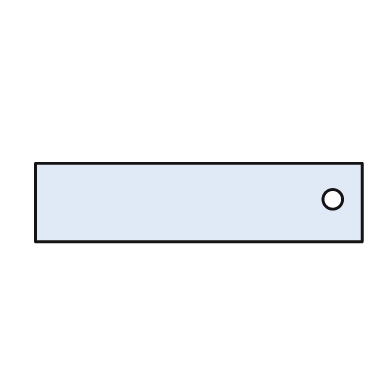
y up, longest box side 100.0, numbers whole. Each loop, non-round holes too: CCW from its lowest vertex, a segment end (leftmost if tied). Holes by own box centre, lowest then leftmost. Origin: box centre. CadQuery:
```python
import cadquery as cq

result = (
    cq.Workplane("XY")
    .moveTo(-50.0, -12.0)
    .lineTo(50.0, -12.0)
    .lineTo(50.0, 12.0)
    .lineTo(-50.0, 12.0)
    .close()
    .moveTo(41.0, 1.0)
    .circle(3.0)
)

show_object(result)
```